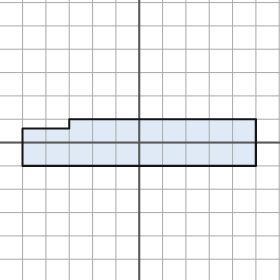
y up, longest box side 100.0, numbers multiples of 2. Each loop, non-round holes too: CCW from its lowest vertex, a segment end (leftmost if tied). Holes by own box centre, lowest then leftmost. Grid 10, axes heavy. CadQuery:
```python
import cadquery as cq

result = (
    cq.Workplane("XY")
    .moveTo(-50.0, -10.0)
    .lineTo(50.0, -10.0)
    .lineTo(50.0, 10.0)
    .lineTo(-30.0, 10.0)
    .lineTo(-30.0, 6.0)
    .lineTo(-50.0, 6.0)
    .close()
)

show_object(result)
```